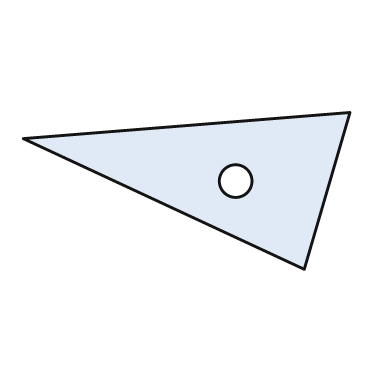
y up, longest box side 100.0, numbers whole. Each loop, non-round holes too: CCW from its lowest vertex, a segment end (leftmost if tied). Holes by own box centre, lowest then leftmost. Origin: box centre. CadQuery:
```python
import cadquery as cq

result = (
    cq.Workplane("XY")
    .moveTo(36.0, -24.0)
    .lineTo(50.0, 24.0)
    .lineTo(-50.0, 16.0)
    .close()
    .moveTo(15.0, 3.0)
    .circle(5.0)
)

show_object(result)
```